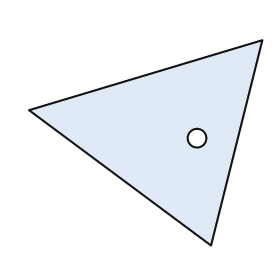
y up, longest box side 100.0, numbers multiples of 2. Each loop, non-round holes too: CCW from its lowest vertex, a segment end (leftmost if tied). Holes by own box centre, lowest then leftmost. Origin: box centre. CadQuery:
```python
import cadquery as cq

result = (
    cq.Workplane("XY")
    .moveTo(28.0, -44.0)
    .lineTo(50.0, 44.0)
    .lineTo(-50.0, 14.0)
    .close()
    .moveTo(22.0, 2.0)
    .circle(4.0)
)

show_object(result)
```